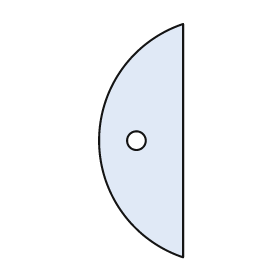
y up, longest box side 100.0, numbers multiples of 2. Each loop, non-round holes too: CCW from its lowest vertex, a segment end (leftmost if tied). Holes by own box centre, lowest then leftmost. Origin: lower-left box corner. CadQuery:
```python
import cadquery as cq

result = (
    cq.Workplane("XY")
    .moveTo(36.0, 0.0)
    .lineTo(36.0, 100.0)
    .threePointArc((0.0, 50.0), (36.0, 0.0))
    .close()
    .moveTo(16.0, 50.0)
    .circle(4.0)
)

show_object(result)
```